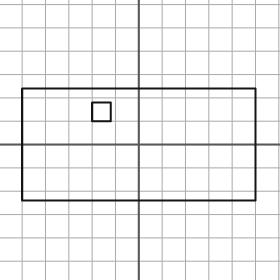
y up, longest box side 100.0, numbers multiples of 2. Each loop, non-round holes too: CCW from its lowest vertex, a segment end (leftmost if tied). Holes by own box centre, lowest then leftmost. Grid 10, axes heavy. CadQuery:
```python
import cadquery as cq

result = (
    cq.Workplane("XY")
    .moveTo(-50.0, -24.0)
    .lineTo(50.0, -24.0)
    .lineTo(50.0, 24.0)
    .lineTo(-50.0, 24.0)
    .close()
    .moveTo(-20.0, 10.0)
    .lineTo(-12.0, 10.0)
    .lineTo(-12.0, 18.0)
    .lineTo(-20.0, 18.0)
    .close()
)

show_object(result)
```